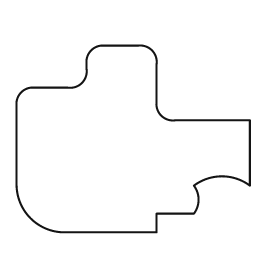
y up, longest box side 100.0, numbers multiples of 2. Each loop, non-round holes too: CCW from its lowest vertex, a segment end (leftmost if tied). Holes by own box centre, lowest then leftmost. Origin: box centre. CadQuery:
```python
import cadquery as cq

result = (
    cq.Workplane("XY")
    .moveTo(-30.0, -40.0)
    .lineTo(10.0, -40.0)
    .lineTo(10.0, -32.0)
    .lineTo(26.0, -32.0)
    .threePointArc((28.0, -26.0), (26.0, -20.0))
    .threePointArc((38.0, -16.0), (50.0, -20.0))
    .lineTo(50.0, 8.0)
    .lineTo(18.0, 8.0)
    .threePointArc((12.0, 10.0), (10.0, 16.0))
    .lineTo(10.0, 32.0)
    .threePointArc((8.0, 38.0), (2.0, 40.0))
    .lineTo(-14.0, 40.0)
    .threePointArc((-18.0, 38.0), (-20.0, 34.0))
    .lineTo(-20.0, 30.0)
    .threePointArc((-22.0, 24.0), (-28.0, 22.0))
    .lineTo(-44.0, 22.0)
    .threePointArc((-48.0, 20.0), (-50.0, 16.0))
    .lineTo(-50.0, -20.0)
    .threePointArc((-44.0, -34.0), (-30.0, -40.0))
    .close()
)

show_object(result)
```